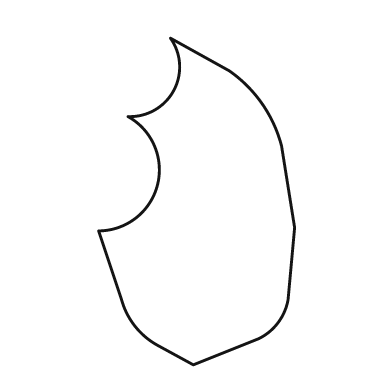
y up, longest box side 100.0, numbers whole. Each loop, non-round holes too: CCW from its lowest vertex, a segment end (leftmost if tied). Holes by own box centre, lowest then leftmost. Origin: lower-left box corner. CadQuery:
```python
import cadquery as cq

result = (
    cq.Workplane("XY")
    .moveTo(29.0, 0.0)
    .lineTo(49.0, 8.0)
    .threePointArc((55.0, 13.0), (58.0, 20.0))
    .lineTo(60.0, 42.0)
    .lineTo(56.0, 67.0)
    .threePointArc((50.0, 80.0), (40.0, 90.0))
    .lineTo(22.0, 100.0)
    .threePointArc((23.0, 84.0), (9.0, 76.0))
    .threePointArc((18.0, 55.0), (0.0, 41.0))
    .lineTo(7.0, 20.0)
    .threePointArc((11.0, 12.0), (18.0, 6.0))
    .close()
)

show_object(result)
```